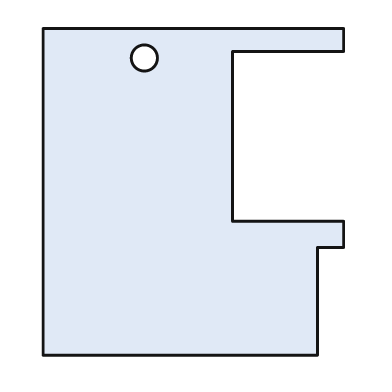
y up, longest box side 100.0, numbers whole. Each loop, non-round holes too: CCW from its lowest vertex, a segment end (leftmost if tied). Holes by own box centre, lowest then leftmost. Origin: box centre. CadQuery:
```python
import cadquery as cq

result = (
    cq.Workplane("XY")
    .moveTo(-46.0, -50.0)
    .lineTo(38.0, -50.0)
    .lineTo(38.0, -17.0)
    .lineTo(46.0, -17.0)
    .lineTo(46.0, -9.0)
    .lineTo(12.0, -9.0)
    .lineTo(12.0, 43.0)
    .lineTo(46.0, 43.0)
    .lineTo(46.0, 50.0)
    .lineTo(-46.0, 50.0)
    .close()
    .moveTo(-15.0, 41.0)
    .circle(4.0)
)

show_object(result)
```